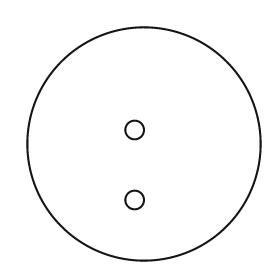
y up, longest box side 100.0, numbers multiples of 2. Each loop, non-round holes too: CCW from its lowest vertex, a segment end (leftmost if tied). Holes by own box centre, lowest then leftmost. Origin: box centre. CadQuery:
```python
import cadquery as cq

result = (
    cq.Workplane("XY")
    .moveTo(0.0, 0.0)
    .circle(50.0)
    .moveTo(-4.0, -24.0)
    .circle(4.0)
    .moveTo(-4.0, 6.0)
    .circle(4.0)
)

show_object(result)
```